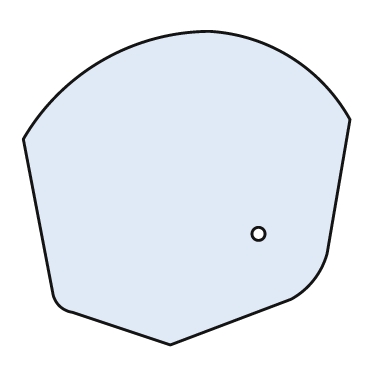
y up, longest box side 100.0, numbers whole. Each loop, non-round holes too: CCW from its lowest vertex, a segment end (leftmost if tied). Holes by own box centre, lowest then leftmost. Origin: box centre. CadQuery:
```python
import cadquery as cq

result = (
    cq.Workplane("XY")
    .moveTo(-5.0, -48.0)
    .lineTo(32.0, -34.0)
    .threePointArc((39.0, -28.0), (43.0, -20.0))
    .lineTo(50.0, 21.0)
    .threePointArc((32.0, 40.0), (7.0, 48.0))
    .threePointArc((-26.0, 39.0), (-50.0, 15.0))
    .lineTo(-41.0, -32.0)
    .threePointArc((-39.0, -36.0), (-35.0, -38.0))
    .close()
    .moveTo(22.0, -14.0)
    .circle(2.0)
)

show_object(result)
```